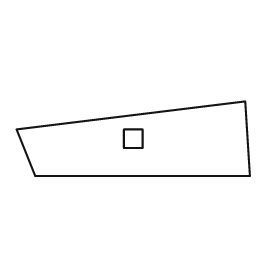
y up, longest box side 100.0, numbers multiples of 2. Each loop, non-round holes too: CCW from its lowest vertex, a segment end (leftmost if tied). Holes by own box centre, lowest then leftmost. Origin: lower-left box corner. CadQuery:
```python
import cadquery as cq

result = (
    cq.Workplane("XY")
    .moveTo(8.0, 0.0)
    .lineTo(100.0, 0.0)
    .lineTo(98.0, 32.0)
    .lineTo(0.0, 20.0)
    .close()
    .moveTo(46.0, 12.0)
    .lineTo(54.0, 12.0)
    .lineTo(54.0, 20.0)
    .lineTo(46.0, 20.0)
    .close()
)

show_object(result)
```